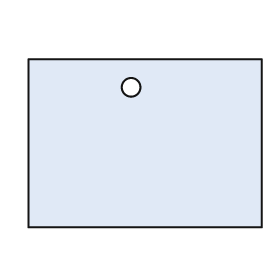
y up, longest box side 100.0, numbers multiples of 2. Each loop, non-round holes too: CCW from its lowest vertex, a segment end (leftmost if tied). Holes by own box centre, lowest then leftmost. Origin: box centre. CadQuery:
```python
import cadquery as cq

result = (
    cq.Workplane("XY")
    .moveTo(-50.0, -36.0)
    .lineTo(50.0, -36.0)
    .lineTo(50.0, 36.0)
    .lineTo(-50.0, 36.0)
    .close()
    .moveTo(-6.0, 24.0)
    .circle(4.0)
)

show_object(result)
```